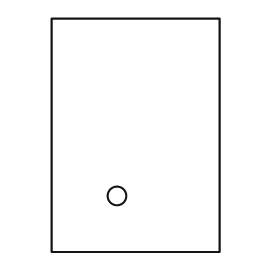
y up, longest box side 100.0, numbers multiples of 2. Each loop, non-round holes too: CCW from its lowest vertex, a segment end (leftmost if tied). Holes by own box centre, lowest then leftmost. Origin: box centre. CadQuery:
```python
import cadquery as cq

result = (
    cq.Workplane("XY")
    .moveTo(-36.0, -50.0)
    .lineTo(36.0, -50.0)
    .lineTo(36.0, 50.0)
    .lineTo(-36.0, 50.0)
    .close()
    .moveTo(-8.0, -26.0)
    .circle(4.0)
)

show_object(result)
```